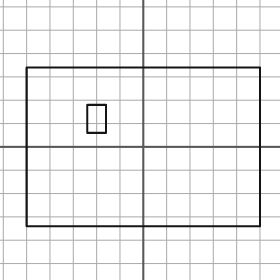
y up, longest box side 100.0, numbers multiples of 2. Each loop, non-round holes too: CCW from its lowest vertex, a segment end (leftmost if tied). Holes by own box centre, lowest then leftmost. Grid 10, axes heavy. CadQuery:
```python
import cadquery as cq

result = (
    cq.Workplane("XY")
    .moveTo(-50.0, -34.0)
    .lineTo(50.0, -34.0)
    .lineTo(50.0, 34.0)
    .lineTo(-50.0, 34.0)
    .close()
    .moveTo(-24.0, 6.0)
    .lineTo(-16.0, 6.0)
    .lineTo(-16.0, 18.0)
    .lineTo(-24.0, 18.0)
    .close()
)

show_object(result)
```